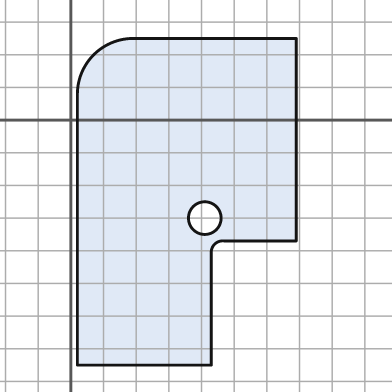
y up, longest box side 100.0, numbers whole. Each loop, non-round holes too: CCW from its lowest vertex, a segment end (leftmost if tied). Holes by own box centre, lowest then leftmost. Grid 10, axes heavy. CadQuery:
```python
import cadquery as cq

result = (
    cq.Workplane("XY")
    .moveTo(2.0, -75.0)
    .lineTo(43.0, -75.0)
    .lineTo(43.0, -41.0)
    .threePointArc((44.0, -38.0), (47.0, -37.0))
    .lineTo(69.0, -37.0)
    .lineTo(69.0, 25.0)
    .lineTo(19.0, 25.0)
    .threePointArc((7.0, 20.0), (2.0, 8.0))
    .close()
    .moveTo(41.0, -30.0)
    .circle(5.0)
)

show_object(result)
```